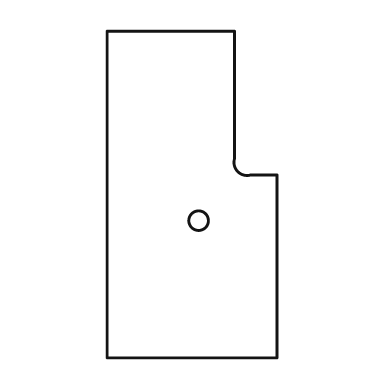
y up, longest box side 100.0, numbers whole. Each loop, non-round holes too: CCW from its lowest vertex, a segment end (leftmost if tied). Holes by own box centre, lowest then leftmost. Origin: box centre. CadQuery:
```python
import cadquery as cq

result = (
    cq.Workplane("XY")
    .moveTo(-26.0, -50.0)
    .lineTo(26.0, -50.0)
    .lineTo(26.0, 6.0)
    .lineTo(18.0, 6.0)
    .threePointArc((14.0, 7.0), (13.0, 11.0))
    .lineTo(13.0, 50.0)
    .lineTo(-26.0, 50.0)
    .close()
    .moveTo(2.0, -8.0)
    .circle(3.0)
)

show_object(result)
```